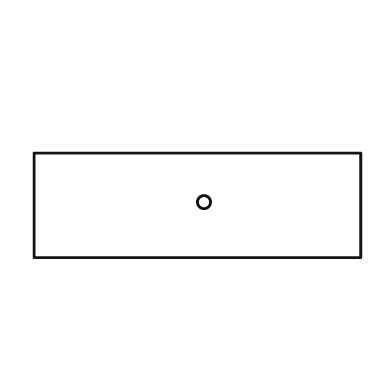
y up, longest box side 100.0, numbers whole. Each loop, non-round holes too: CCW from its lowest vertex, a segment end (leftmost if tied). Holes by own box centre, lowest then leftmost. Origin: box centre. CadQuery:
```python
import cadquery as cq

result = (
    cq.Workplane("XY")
    .moveTo(-50.0, -16.0)
    .lineTo(50.0, -16.0)
    .lineTo(50.0, 16.0)
    .lineTo(-50.0, 16.0)
    .close()
    .moveTo(2.0, 1.0)
    .circle(2.0)
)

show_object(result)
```